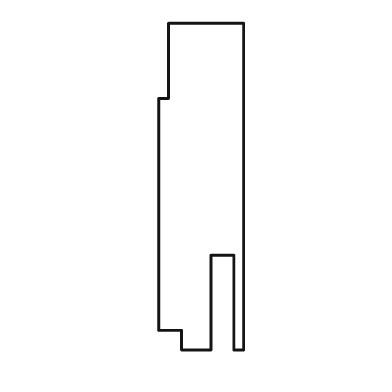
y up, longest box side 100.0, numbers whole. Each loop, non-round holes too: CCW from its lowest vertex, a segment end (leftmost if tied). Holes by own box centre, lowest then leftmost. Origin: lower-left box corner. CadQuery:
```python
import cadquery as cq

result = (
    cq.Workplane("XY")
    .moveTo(7.0, 0.0)
    .lineTo(16.0, 0.0)
    .lineTo(16.0, 29.0)
    .lineTo(23.0, 29.0)
    .lineTo(23.0, 0.0)
    .lineTo(26.0, 0.0)
    .lineTo(26.0, 100.0)
    .lineTo(3.0, 100.0)
    .lineTo(3.0, 77.0)
    .lineTo(0.0, 77.0)
    .lineTo(0.0, 6.0)
    .lineTo(7.0, 6.0)
    .close()
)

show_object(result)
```